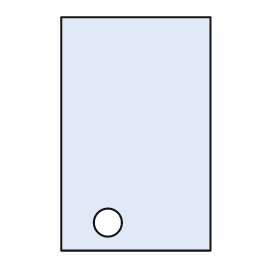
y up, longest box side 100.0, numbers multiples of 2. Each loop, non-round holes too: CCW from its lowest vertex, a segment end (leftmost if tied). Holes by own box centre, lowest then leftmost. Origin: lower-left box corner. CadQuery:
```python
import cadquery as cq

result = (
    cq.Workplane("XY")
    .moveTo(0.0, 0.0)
    .lineTo(64.0, 0.0)
    .lineTo(64.0, 100.0)
    .lineTo(0.0, 100.0)
    .close()
    .moveTo(20.0, 12.0)
    .circle(6.0)
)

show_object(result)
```